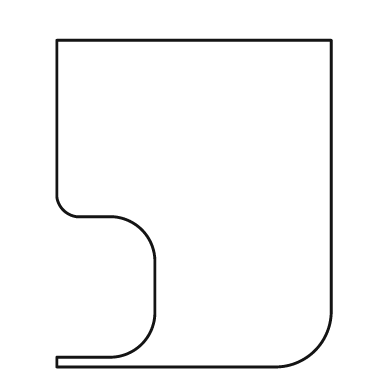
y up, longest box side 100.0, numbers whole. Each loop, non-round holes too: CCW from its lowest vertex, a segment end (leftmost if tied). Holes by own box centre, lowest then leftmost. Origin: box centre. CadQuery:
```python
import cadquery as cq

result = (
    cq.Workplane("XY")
    .moveTo(-42.0, -50.0)
    .lineTo(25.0, -50.0)
    .threePointArc((37.0, -45.0), (42.0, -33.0))
    .lineTo(42.0, 50.0)
    .lineTo(-42.0, 50.0)
    .lineTo(-42.0, 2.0)
    .threePointArc((-40.0, -2.0), (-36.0, -4.0))
    .lineTo(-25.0, -4.0)
    .threePointArc((-16.0, -8.0), (-12.0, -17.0))
    .lineTo(-12.0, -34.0)
    .threePointArc((-16.0, -43.0), (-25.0, -47.0))
    .lineTo(-42.0, -47.0)
    .close()
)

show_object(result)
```